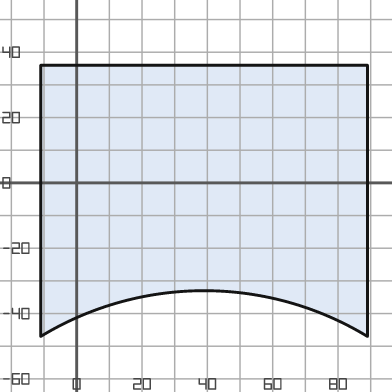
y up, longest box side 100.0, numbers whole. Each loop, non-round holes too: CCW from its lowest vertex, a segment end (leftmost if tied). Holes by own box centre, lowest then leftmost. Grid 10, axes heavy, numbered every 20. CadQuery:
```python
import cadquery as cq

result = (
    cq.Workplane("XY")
    .moveTo(-11.0, -47.0)
    .threePointArc((39.0, -33.0), (89.0, -47.0))
    .lineTo(89.0, 36.0)
    .lineTo(-11.0, 36.0)
    .close()
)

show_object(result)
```